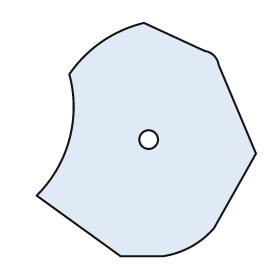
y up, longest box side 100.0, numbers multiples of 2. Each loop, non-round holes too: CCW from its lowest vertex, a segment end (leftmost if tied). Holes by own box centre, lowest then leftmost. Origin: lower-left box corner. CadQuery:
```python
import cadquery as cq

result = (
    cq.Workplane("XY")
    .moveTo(36.0, 0.0)
    .lineTo(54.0, 0.0)
    .threePointArc((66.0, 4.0), (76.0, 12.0))
    .lineTo(94.0, 44.0)
    .lineTo(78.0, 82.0)
    .threePointArc((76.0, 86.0), (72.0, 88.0))
    .lineTo(46.0, 100.0)
    .threePointArc((28.0, 92.0), (14.0, 78.0))
    .threePointArc((14.0, 50.0), (0.0, 26.0))
    .close()
    .moveTo(48.0, 50.0)
    .circle(4.0)
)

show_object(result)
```